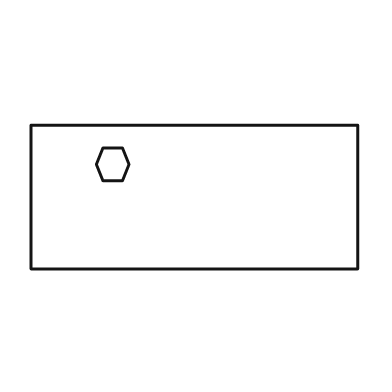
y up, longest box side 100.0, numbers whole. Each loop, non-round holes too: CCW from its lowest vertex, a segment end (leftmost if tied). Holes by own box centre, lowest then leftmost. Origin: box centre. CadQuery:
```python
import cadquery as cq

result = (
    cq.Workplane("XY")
    .moveTo(-50.0, -22.0)
    .lineTo(50.0, -22.0)
    .lineTo(50.0, 22.0)
    .lineTo(-50.0, 22.0)
    .close()
    .moveTo(-28.0, 5.0)
    .lineTo(-22.0, 5.0)
    .lineTo(-20.0, 10.0)
    .lineTo(-22.0, 15.0)
    .lineTo(-28.0, 15.0)
    .lineTo(-30.0, 10.0)
    .close()
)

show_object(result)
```